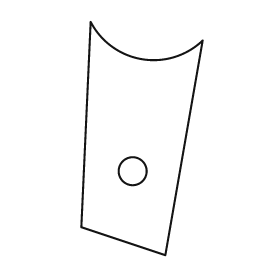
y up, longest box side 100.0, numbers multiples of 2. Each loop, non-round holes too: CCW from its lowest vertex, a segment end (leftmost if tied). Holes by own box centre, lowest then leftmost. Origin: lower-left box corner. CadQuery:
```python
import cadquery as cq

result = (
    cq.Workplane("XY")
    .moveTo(36.0, 0.0)
    .lineTo(52.0, 92.0)
    .threePointArc((26.0, 84.0), (4.0, 100.0))
    .lineTo(0.0, 12.0)
    .close()
    .moveTo(22.0, 36.0)
    .circle(6.0)
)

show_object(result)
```